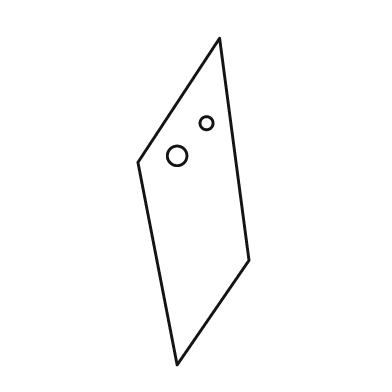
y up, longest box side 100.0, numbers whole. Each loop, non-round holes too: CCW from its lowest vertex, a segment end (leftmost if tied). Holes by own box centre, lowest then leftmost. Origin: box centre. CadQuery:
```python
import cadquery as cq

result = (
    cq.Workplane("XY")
    .moveTo(-5.0, -50.0)
    .lineTo(17.0, -18.0)
    .lineTo(8.0, 50.0)
    .lineTo(-17.0, 12.0)
    .close()
    .moveTo(-5.0, 14.0)
    .circle(3.0)
    .moveTo(4.0, 24.0)
    .circle(2.0)
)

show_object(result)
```